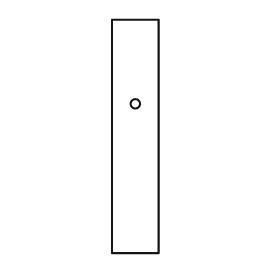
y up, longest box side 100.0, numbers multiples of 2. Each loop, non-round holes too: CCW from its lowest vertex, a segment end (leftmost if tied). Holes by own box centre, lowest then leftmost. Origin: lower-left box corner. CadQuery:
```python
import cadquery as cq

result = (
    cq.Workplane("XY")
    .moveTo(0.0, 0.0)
    .lineTo(20.0, 0.0)
    .lineTo(20.0, 100.0)
    .lineTo(0.0, 100.0)
    .close()
    .moveTo(10.0, 64.0)
    .circle(2.0)
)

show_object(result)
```